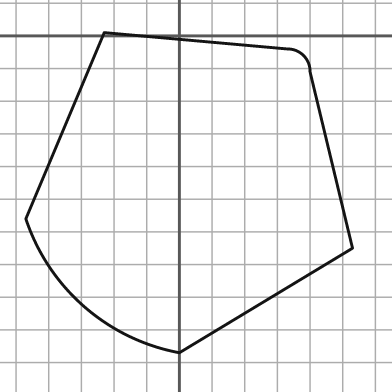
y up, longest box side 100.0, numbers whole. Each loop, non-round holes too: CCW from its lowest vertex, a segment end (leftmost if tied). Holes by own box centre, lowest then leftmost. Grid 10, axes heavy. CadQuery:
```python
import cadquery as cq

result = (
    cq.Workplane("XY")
    .moveTo(0.0, -97.0)
    .lineTo(53.0, -65.0)
    .lineTo(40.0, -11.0)
    .threePointArc((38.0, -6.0), (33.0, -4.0))
    .lineTo(-23.0, 1.0)
    .lineTo(-47.0, -56.0)
    .threePointArc((-29.0, -83.0), (0.0, -97.0))
    .close()
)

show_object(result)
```